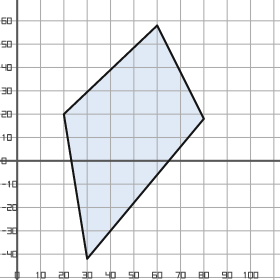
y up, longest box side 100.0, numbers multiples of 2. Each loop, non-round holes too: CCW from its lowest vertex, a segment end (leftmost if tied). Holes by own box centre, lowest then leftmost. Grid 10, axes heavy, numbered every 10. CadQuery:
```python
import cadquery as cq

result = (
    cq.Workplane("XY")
    .moveTo(30.0, -42.0)
    .lineTo(80.0, 18.0)
    .lineTo(60.0, 58.0)
    .lineTo(20.0, 20.0)
    .close()
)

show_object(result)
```